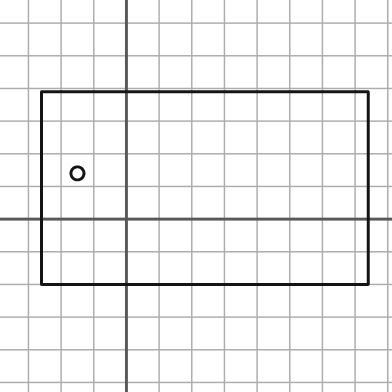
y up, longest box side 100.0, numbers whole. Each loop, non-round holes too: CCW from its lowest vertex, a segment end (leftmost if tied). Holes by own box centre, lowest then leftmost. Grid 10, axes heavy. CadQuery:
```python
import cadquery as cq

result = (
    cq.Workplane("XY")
    .moveTo(-26.0, -20.0)
    .lineTo(74.0, -20.0)
    .lineTo(74.0, 39.0)
    .lineTo(-26.0, 39.0)
    .close()
    .moveTo(-15.0, 14.0)
    .circle(2.0)
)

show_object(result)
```